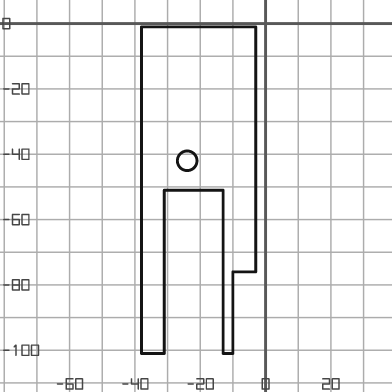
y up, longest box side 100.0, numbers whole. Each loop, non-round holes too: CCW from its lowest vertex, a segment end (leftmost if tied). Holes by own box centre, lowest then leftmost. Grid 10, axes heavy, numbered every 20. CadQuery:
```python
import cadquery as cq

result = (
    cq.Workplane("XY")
    .moveTo(-38.0, -101.0)
    .lineTo(-31.0, -101.0)
    .lineTo(-31.0, -51.0)
    .lineTo(-13.0, -51.0)
    .lineTo(-13.0, -101.0)
    .lineTo(-10.0, -101.0)
    .lineTo(-10.0, -76.0)
    .lineTo(-3.0, -76.0)
    .lineTo(-3.0, -1.0)
    .lineTo(-38.0, -1.0)
    .close()
    .moveTo(-24.0, -42.0)
    .circle(3.0)
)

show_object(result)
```